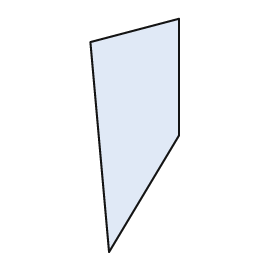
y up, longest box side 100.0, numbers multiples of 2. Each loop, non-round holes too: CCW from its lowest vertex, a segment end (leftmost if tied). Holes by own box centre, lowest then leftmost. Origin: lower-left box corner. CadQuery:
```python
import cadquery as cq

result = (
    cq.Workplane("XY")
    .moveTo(8.0, 0.0)
    .lineTo(38.0, 50.0)
    .lineTo(38.0, 100.0)
    .lineTo(0.0, 90.0)
    .close()
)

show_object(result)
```